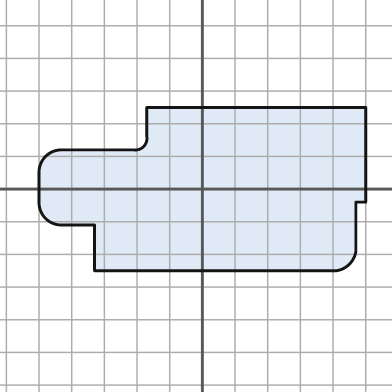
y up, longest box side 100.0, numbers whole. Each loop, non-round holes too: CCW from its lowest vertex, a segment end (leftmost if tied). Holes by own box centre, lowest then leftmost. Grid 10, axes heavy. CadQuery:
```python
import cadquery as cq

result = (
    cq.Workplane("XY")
    .moveTo(-33.0, -25.0)
    .lineTo(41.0, -25.0)
    .threePointArc((45.0, -23.0), (47.0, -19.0))
    .lineTo(47.0, -4.0)
    .lineTo(50.0, -4.0)
    .lineTo(50.0, 25.0)
    .lineTo(-17.0, 25.0)
    .lineTo(-17.0, 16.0)
    .threePointArc((-18.0, 13.0), (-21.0, 12.0))
    .lineTo(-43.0, 12.0)
    .threePointArc((-48.0, 10.0), (-50.0, 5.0))
    .lineTo(-50.0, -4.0)
    .threePointArc((-48.0, -9.0), (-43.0, -11.0))
    .lineTo(-33.0, -11.0)
    .close()
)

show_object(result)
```